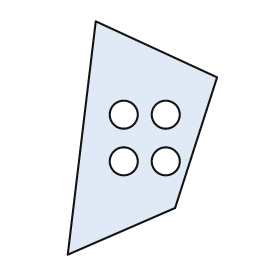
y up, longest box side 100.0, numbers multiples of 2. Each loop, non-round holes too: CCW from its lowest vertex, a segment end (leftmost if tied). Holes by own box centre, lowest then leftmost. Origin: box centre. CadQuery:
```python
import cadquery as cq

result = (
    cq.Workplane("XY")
    .moveTo(-32.0, -50.0)
    .lineTo(14.0, -30.0)
    .lineTo(32.0, 26.0)
    .lineTo(-20.0, 50.0)
    .close()
    .moveTo(-8.0, -10.0)
    .circle(6.0)
    .moveTo(10.0, -10.0)
    .circle(6.0)
    .moveTo(-8.0, 10.0)
    .circle(6.0)
    .moveTo(10.0, 10.0)
    .circle(6.0)
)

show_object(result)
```